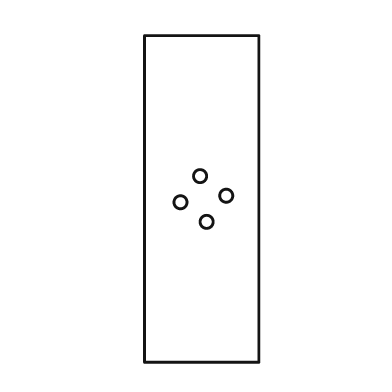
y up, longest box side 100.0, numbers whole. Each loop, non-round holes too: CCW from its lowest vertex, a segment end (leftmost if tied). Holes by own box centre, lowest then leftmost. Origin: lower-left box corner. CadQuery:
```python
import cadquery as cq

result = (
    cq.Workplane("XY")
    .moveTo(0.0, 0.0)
    .lineTo(35.0, 0.0)
    .lineTo(35.0, 100.0)
    .lineTo(0.0, 100.0)
    .close()
    .moveTo(19.0, 43.0)
    .circle(2.0)
    .moveTo(11.0, 49.0)
    .circle(2.0)
    .moveTo(25.0, 51.0)
    .circle(2.0)
    .moveTo(17.0, 57.0)
    .circle(2.0)
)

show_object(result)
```